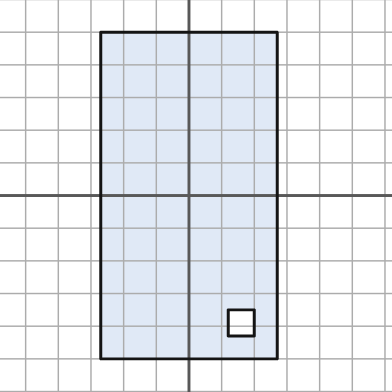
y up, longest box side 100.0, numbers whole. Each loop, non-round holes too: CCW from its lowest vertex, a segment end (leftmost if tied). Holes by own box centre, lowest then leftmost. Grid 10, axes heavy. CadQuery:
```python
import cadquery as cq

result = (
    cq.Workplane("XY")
    .moveTo(-27.0, -50.0)
    .lineTo(27.0, -50.0)
    .lineTo(27.0, 50.0)
    .lineTo(-27.0, 50.0)
    .close()
    .moveTo(12.0, -43.0)
    .lineTo(20.0, -43.0)
    .lineTo(20.0, -35.0)
    .lineTo(12.0, -35.0)
    .close()
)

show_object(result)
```